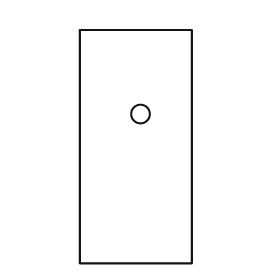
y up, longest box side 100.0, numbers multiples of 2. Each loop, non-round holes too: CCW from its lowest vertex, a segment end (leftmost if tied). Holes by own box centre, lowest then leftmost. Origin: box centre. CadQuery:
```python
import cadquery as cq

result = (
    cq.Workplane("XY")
    .moveTo(-24.0, -50.0)
    .lineTo(24.0, -50.0)
    .lineTo(24.0, 50.0)
    .lineTo(-24.0, 50.0)
    .close()
    .moveTo(2.0, 14.0)
    .circle(4.0)
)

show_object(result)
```